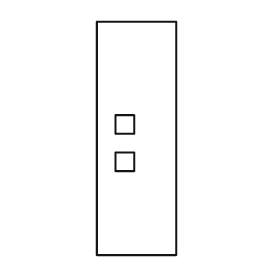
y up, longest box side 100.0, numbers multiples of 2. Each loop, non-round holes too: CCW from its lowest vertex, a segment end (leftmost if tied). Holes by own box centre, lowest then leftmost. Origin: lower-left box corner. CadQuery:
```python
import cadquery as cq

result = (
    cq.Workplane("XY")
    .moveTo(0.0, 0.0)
    .lineTo(34.0, 0.0)
    .lineTo(34.0, 100.0)
    .lineTo(0.0, 100.0)
    .close()
    .moveTo(8.0, 36.0)
    .lineTo(16.0, 36.0)
    .lineTo(16.0, 44.0)
    .lineTo(8.0, 44.0)
    .close()
    .moveTo(8.0, 52.0)
    .lineTo(16.0, 52.0)
    .lineTo(16.0, 60.0)
    .lineTo(8.0, 60.0)
    .close()
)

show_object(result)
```